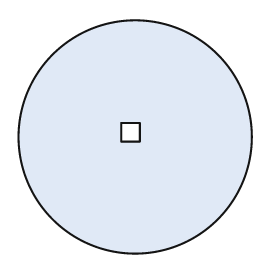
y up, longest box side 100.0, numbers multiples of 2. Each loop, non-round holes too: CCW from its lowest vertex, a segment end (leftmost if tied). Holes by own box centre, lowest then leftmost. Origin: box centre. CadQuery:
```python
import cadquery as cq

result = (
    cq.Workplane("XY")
    .moveTo(0.0, 0.0)
    .circle(50.0)
    .moveTo(-6.0, -2.0)
    .lineTo(2.0, -2.0)
    .lineTo(2.0, 6.0)
    .lineTo(-6.0, 6.0)
    .close()
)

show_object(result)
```